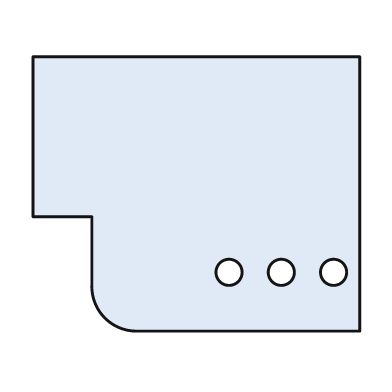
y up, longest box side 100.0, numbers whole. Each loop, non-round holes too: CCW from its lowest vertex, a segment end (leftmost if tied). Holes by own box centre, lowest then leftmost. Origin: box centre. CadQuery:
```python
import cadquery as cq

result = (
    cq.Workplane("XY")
    .moveTo(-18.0, -42.0)
    .lineTo(50.0, -42.0)
    .lineTo(50.0, 42.0)
    .lineTo(-50.0, 42.0)
    .lineTo(-50.0, -7.0)
    .lineTo(-32.0, -7.0)
    .lineTo(-32.0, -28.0)
    .threePointArc((-28.0, -38.0), (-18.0, -42.0))
    .close()
    .moveTo(10.0, -24.0)
    .circle(4.0)
    .moveTo(26.0, -24.0)
    .circle(4.0)
    .moveTo(42.0, -24.0)
    .circle(4.0)
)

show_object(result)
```